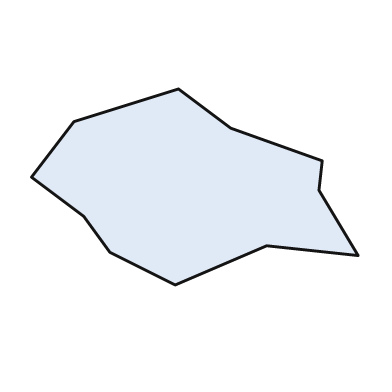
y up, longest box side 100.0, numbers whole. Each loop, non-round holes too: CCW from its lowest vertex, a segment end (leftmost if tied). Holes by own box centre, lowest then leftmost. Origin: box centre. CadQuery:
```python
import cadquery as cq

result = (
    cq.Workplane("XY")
    .moveTo(-6.0, -30.0)
    .lineTo(22.0, -18.0)
    .lineTo(50.0, -21.0)
    .lineTo(38.0, -1.0)
    .lineTo(39.0, 8.0)
    .lineTo(11.0, 18.0)
    .lineTo(-5.0, 30.0)
    .lineTo(-37.0, 20.0)
    .lineTo(-50.0, 3.0)
    .lineTo(-34.0, -9.0)
    .lineTo(-26.0, -20.0)
    .close()
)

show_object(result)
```